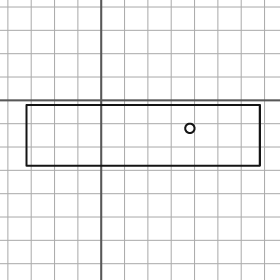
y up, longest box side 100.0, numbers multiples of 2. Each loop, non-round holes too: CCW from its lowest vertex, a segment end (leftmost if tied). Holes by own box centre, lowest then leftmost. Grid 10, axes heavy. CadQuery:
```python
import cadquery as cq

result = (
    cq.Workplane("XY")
    .moveTo(-32.0, -28.0)
    .lineTo(68.0, -28.0)
    .lineTo(68.0, -2.0)
    .lineTo(-32.0, -2.0)
    .close()
    .moveTo(38.0, -12.0)
    .circle(2.0)
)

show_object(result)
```